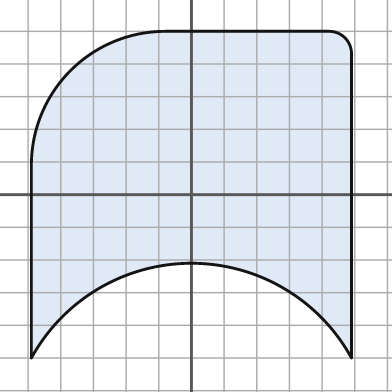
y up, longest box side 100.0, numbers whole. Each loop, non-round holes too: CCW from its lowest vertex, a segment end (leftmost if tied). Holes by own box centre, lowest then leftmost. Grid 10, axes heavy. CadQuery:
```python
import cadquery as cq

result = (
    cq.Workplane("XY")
    .moveTo(-49.0, -50.0)
    .threePointArc((0.0, -21.0), (49.0, -50.0))
    .lineTo(49.0, 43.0)
    .threePointArc((47.0, 48.0), (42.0, 50.0))
    .lineTo(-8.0, 50.0)
    .threePointArc((-37.0, 38.0), (-49.0, 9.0))
    .close()
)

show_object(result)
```